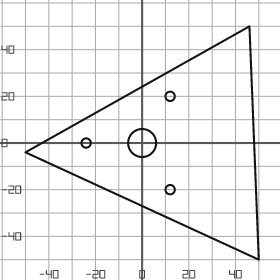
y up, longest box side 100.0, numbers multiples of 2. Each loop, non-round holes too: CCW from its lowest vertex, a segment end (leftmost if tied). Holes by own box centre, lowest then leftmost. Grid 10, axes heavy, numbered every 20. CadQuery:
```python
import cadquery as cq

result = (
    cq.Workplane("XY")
    .moveTo(50.0, -50.0)
    .lineTo(46.0, 50.0)
    .lineTo(-50.0, -4.0)
    .close()
    .moveTo(12.0, -20.0)
    .circle(2.0)
    .moveTo(-24.0, 0.0)
    .circle(2.0)
    .moveTo(0.0, 0.0)
    .circle(6.0)
    .moveTo(12.0, 20.0)
    .circle(2.0)
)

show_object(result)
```